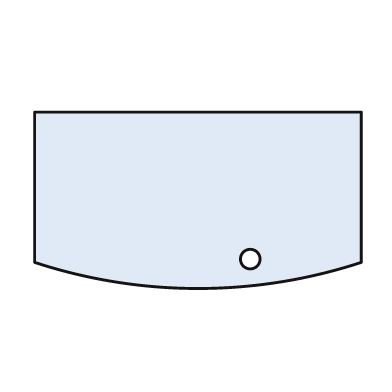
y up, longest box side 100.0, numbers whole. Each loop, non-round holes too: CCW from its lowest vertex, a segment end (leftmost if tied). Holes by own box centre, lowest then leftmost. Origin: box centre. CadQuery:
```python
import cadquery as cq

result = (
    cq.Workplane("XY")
    .moveTo(-50.0, -19.0)
    .threePointArc((0.0, -27.0), (50.0, -19.0))
    .lineTo(50.0, 27.0)
    .lineTo(-50.0, 27.0)
    .close()
    .moveTo(16.0, -18.0)
    .circle(3.0)
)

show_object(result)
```